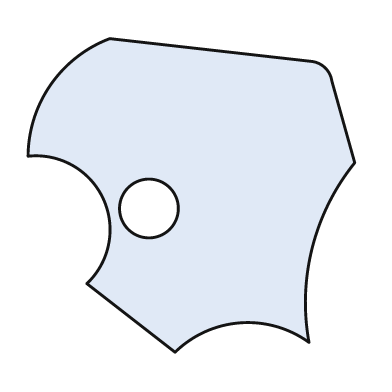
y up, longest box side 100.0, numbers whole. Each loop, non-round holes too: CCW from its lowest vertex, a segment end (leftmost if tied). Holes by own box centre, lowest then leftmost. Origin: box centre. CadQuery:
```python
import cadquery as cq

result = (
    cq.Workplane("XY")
    .moveTo(-5.0, -48.0)
    .threePointArc((15.0, -39.0), (36.0, -45.0))
    .threePointArc((37.0, -16.0), (50.0, 10.0))
    .lineTo(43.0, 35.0)
    .threePointArc((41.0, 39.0), (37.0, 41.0))
    .lineTo(-25.0, 48.0)
    .threePointArc((-43.0, 34.0), (-50.0, 12.0))
    .threePointArc((-27.0, -1.0), (-32.0, -27.0))
    .close()
    .moveTo(-13.0, -4.0)
    .circle(9.0)
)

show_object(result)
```